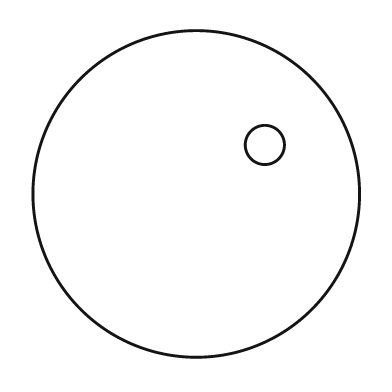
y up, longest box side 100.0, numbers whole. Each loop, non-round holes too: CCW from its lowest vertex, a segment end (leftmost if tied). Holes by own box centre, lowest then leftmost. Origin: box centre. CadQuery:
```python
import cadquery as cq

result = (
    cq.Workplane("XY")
    .moveTo(0.0, 0.0)
    .circle(50.0)
    .moveTo(21.0, 15.0)
    .circle(6.0)
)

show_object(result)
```